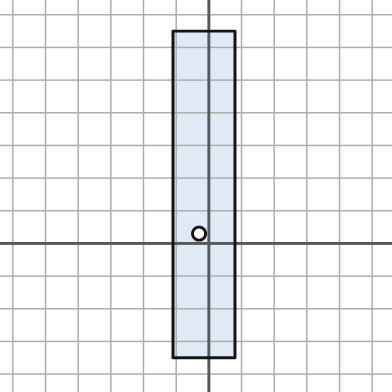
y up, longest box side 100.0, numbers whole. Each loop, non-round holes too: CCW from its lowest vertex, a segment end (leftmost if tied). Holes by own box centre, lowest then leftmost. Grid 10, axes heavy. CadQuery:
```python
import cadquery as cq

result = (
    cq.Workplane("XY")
    .moveTo(-11.0, -35.0)
    .lineTo(8.0, -35.0)
    .lineTo(8.0, 65.0)
    .lineTo(-11.0, 65.0)
    .close()
    .moveTo(-3.0, 3.0)
    .circle(2.0)
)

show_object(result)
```